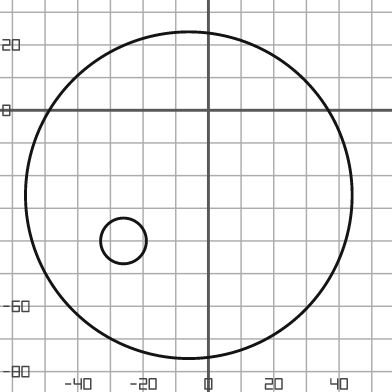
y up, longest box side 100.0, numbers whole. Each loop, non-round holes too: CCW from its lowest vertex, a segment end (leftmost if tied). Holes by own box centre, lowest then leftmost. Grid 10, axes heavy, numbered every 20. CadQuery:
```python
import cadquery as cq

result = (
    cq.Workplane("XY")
    .moveTo(-6.0, -26.0)
    .circle(50.0)
    .moveTo(-26.0, -40.0)
    .circle(7.0)
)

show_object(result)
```